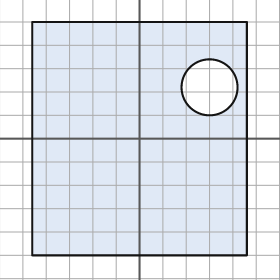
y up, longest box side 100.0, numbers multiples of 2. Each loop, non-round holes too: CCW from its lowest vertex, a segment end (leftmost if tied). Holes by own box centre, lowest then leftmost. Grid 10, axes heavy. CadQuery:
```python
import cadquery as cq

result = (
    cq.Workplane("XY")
    .moveTo(-46.0, -50.0)
    .lineTo(46.0, -50.0)
    .lineTo(46.0, 50.0)
    .lineTo(-46.0, 50.0)
    .close()
    .moveTo(30.0, 22.0)
    .circle(12.0)
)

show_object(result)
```